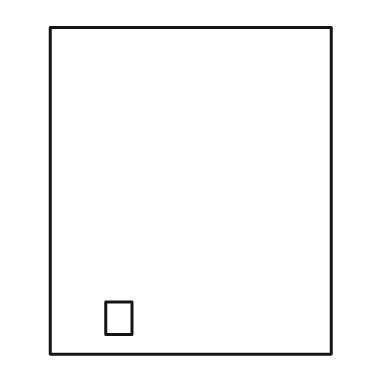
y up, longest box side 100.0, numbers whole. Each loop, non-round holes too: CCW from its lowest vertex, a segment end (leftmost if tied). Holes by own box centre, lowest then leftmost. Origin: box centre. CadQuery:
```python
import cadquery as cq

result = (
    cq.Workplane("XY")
    .moveTo(-43.0, -50.0)
    .lineTo(43.0, -50.0)
    .lineTo(43.0, 50.0)
    .lineTo(-43.0, 50.0)
    .close()
    .moveTo(-26.0, -44.0)
    .lineTo(-18.0, -44.0)
    .lineTo(-18.0, -34.0)
    .lineTo(-26.0, -34.0)
    .close()
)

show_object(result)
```